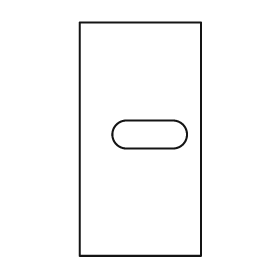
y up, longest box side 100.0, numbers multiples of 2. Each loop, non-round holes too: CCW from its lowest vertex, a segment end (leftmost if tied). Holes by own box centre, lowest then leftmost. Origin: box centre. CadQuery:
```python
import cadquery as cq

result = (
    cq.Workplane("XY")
    .moveTo(-26.0, -50.0)
    .lineTo(26.0, -50.0)
    .lineTo(26.0, 50.0)
    .lineTo(-26.0, 50.0)
    .close()
    .moveTo(-6.0, -4.0)
    .lineTo(14.0, -4.0)
    .threePointArc((20.0, 2.0), (14.0, 8.0))
    .lineTo(-6.0, 8.0)
    .threePointArc((-12.0, 2.0), (-6.0, -4.0))
    .close()
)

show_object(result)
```